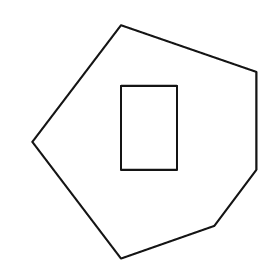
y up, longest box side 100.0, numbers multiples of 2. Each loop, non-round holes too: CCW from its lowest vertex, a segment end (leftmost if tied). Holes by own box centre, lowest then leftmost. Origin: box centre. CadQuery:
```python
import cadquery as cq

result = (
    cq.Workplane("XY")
    .moveTo(-10.0, -50.0)
    .lineTo(30.0, -36.0)
    .lineTo(48.0, -12.0)
    .lineTo(48.0, 30.0)
    .lineTo(-10.0, 50.0)
    .lineTo(-48.0, 0.0)
    .close()
    .moveTo(-10.0, -12.0)
    .lineTo(14.0, -12.0)
    .lineTo(14.0, 24.0)
    .lineTo(-10.0, 24.0)
    .close()
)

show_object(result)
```